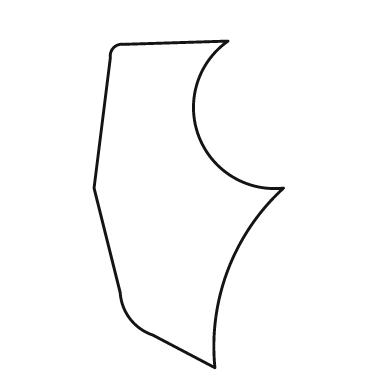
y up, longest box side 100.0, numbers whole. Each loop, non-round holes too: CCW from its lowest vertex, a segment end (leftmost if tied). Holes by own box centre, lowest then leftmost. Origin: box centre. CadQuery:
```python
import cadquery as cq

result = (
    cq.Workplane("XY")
    .moveTo(8.0, -50.0)
    .threePointArc((12.0, -20.0), (29.0, 5.0))
    .threePointArc((3.0, 21.0), (12.0, 50.0))
    .lineTo(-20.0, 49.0)
    .threePointArc((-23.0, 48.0), (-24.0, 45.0))
    .lineTo(-29.0, 5.0)
    .lineTo(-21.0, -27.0)
    .threePointArc((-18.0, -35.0), (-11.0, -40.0))
    .close()
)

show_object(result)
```